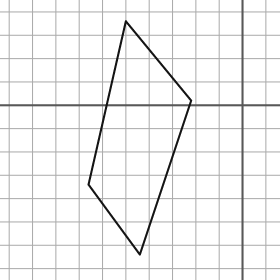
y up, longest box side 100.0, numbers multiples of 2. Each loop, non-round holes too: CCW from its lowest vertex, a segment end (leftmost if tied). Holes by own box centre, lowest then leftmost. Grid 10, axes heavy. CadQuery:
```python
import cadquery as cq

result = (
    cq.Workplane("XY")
    .moveTo(-44.0, -64.0)
    .lineTo(-22.0, 2.0)
    .lineTo(-50.0, 36.0)
    .lineTo(-66.0, -34.0)
    .close()
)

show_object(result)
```